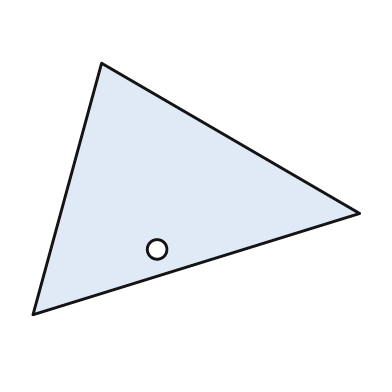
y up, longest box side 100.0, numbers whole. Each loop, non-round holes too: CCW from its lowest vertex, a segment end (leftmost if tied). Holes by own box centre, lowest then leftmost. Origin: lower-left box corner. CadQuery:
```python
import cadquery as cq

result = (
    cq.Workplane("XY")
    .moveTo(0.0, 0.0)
    .lineTo(100.0, 31.0)
    .lineTo(21.0, 77.0)
    .close()
    .moveTo(38.0, 20.0)
    .circle(3.0)
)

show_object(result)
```